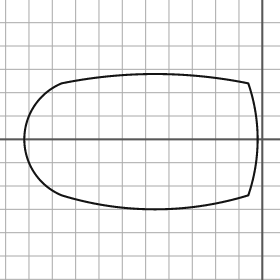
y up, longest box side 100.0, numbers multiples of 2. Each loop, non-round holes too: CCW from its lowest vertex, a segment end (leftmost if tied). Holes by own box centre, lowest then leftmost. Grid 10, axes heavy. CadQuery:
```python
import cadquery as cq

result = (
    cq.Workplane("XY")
    .moveTo(-86.0, -24.0)
    .threePointArc((-46.0, -30.0), (-6.0, -24.0))
    .threePointArc((-2.0, 0.0), (-6.0, 24.0))
    .threePointArc((-46.0, 28.0), (-86.0, 24.0))
    .threePointArc((-102.0, 0.0), (-86.0, -24.0))
    .close()
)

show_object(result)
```